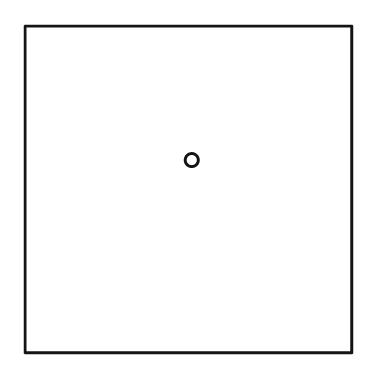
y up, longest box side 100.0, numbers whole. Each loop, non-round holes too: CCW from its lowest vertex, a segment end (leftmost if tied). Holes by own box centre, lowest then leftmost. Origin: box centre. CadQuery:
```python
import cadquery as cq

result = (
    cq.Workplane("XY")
    .moveTo(-50.0, -50.0)
    .lineTo(50.0, -50.0)
    .lineTo(50.0, 50.0)
    .lineTo(-50.0, 50.0)
    .close()
    .moveTo(1.0, 9.0)
    .circle(2.0)
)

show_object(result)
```